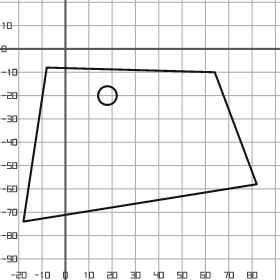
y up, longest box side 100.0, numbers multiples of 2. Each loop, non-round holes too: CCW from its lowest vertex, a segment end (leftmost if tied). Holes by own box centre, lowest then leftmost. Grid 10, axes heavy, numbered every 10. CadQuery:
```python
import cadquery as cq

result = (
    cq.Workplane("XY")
    .moveTo(-18.0, -74.0)
    .lineTo(82.0, -58.0)
    .lineTo(64.0, -10.0)
    .lineTo(-8.0, -8.0)
    .close()
    .moveTo(18.0, -20.0)
    .circle(4.0)
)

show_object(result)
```